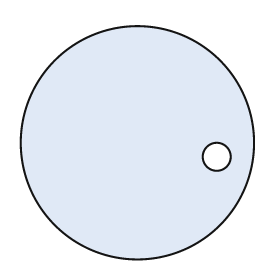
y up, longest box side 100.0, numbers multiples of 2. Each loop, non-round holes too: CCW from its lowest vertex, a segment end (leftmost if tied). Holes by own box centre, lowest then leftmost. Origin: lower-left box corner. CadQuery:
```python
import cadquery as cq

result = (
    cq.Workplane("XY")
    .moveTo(50.0, 50.0)
    .circle(50.0)
    .moveTo(84.0, 44.0)
    .circle(6.0)
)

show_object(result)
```